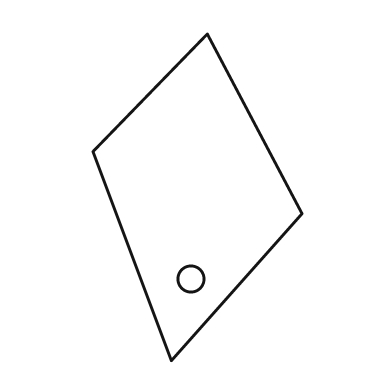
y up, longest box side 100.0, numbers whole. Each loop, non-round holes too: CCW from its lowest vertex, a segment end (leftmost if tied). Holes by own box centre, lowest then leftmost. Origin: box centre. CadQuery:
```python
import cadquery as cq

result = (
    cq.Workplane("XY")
    .moveTo(-8.0, -50.0)
    .lineTo(32.0, -5.0)
    .lineTo(3.0, 50.0)
    .lineTo(-32.0, 14.0)
    .close()
    .moveTo(-2.0, -25.0)
    .circle(4.0)
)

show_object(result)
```